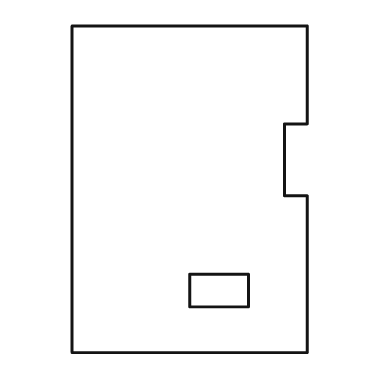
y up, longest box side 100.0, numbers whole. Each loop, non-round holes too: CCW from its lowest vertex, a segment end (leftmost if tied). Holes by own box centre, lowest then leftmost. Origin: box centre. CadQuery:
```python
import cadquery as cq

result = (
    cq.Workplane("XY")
    .moveTo(-36.0, -50.0)
    .lineTo(36.0, -50.0)
    .lineTo(36.0, -2.0)
    .lineTo(29.0, -2.0)
    .lineTo(29.0, 20.0)
    .lineTo(36.0, 20.0)
    .lineTo(36.0, 50.0)
    .lineTo(-36.0, 50.0)
    .close()
    .moveTo(0.0, -36.0)
    .lineTo(18.0, -36.0)
    .lineTo(18.0, -26.0)
    .lineTo(0.0, -26.0)
    .close()
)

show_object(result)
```